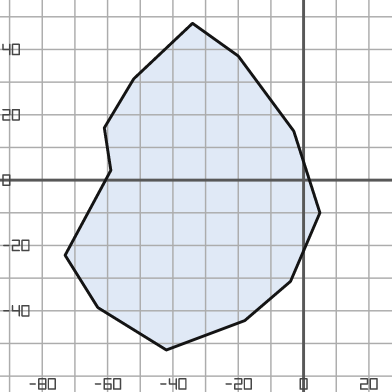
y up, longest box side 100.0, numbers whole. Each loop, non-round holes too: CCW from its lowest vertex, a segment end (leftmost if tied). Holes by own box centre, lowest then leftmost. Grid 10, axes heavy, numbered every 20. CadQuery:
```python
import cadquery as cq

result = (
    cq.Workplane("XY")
    .moveTo(-42.0, -52.0)
    .lineTo(-18.0, -43.0)
    .lineTo(-4.0, -31.0)
    .lineTo(5.0, -10.0)
    .lineTo(-3.0, 15.0)
    .lineTo(-20.0, 38.0)
    .lineTo(-34.0, 48.0)
    .lineTo(-52.0, 31.0)
    .lineTo(-61.0, 16.0)
    .lineTo(-59.0, 3.0)
    .lineTo(-73.0, -23.0)
    .lineTo(-63.0, -39.0)
    .close()
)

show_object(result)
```